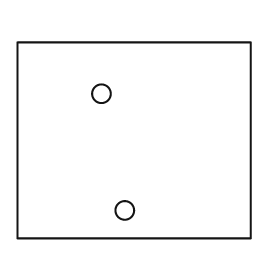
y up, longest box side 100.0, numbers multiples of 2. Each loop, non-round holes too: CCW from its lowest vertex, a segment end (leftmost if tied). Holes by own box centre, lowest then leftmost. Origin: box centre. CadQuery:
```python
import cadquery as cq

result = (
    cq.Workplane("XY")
    .moveTo(-50.0, -42.0)
    .lineTo(50.0, -42.0)
    .lineTo(50.0, 42.0)
    .lineTo(-50.0, 42.0)
    .close()
    .moveTo(-4.0, -30.0)
    .circle(4.0)
    .moveTo(-14.0, 20.0)
    .circle(4.0)
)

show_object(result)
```